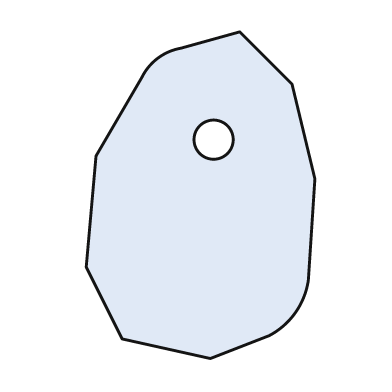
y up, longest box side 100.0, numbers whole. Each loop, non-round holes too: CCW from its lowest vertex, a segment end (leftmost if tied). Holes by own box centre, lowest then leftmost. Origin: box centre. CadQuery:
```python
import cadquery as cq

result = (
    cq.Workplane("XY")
    .moveTo(3.0, -50.0)
    .lineTo(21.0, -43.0)
    .threePointArc((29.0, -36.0), (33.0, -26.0))
    .lineTo(35.0, 5.0)
    .lineTo(28.0, 34.0)
    .lineTo(12.0, 50.0)
    .lineTo(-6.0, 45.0)
    .threePointArc((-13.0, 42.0), (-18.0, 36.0))
    .lineTo(-32.0, 12.0)
    .lineTo(-35.0, -22.0)
    .lineTo(-24.0, -44.0)
    .close()
    .moveTo(4.0, 17.0)
    .circle(6.0)
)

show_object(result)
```